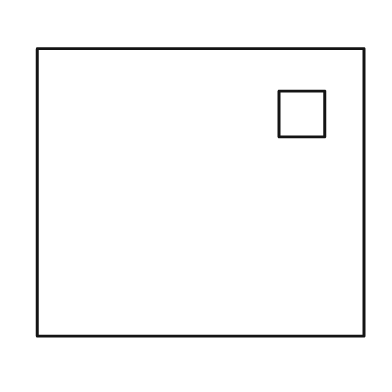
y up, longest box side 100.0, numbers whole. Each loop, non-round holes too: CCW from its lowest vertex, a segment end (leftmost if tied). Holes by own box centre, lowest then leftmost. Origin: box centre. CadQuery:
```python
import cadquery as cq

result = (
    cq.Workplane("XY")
    .moveTo(-50.0, -44.0)
    .lineTo(50.0, -44.0)
    .lineTo(50.0, 44.0)
    .lineTo(-50.0, 44.0)
    .close()
    .moveTo(24.0, 17.0)
    .lineTo(38.0, 17.0)
    .lineTo(38.0, 31.0)
    .lineTo(24.0, 31.0)
    .close()
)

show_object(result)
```